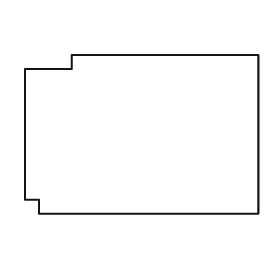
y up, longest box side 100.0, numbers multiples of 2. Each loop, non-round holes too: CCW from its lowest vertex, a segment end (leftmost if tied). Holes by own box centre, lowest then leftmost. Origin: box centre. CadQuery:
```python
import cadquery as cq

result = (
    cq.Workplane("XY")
    .moveTo(-44.0, -34.0)
    .lineTo(50.0, -34.0)
    .lineTo(50.0, 34.0)
    .lineTo(-30.0, 34.0)
    .lineTo(-30.0, 28.0)
    .lineTo(-50.0, 28.0)
    .lineTo(-50.0, -28.0)
    .lineTo(-44.0, -28.0)
    .close()
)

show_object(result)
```